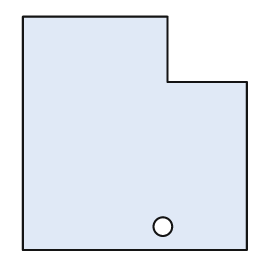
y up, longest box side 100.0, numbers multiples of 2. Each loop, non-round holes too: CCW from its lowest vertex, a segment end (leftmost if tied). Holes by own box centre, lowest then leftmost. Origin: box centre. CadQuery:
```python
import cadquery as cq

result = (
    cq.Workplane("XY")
    .moveTo(-48.0, -50.0)
    .lineTo(48.0, -50.0)
    .lineTo(48.0, 22.0)
    .lineTo(14.0, 22.0)
    .lineTo(14.0, 50.0)
    .lineTo(-48.0, 50.0)
    .close()
    .moveTo(12.0, -40.0)
    .circle(4.0)
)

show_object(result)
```